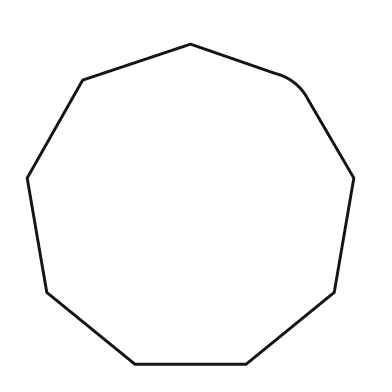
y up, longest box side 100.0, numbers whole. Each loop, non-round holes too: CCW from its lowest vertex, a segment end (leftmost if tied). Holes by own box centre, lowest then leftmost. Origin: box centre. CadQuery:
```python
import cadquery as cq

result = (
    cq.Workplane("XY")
    .moveTo(-17.0, -49.0)
    .lineTo(17.0, -49.0)
    .lineTo(44.0, -27.0)
    .lineTo(50.0, 8.0)
    .lineTo(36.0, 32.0)
    .threePointArc((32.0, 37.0), (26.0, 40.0))
    .lineTo(0.0, 49.0)
    .lineTo(-33.0, 38.0)
    .lineTo(-50.0, 8.0)
    .lineTo(-44.0, -27.0)
    .close()
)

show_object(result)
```